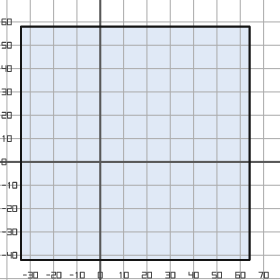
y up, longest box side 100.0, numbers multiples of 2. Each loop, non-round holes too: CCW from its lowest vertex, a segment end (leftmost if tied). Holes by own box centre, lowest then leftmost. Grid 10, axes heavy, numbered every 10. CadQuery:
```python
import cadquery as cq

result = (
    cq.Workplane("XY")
    .moveTo(-34.0, -42.0)
    .lineTo(64.0, -42.0)
    .lineTo(64.0, 58.0)
    .lineTo(-34.0, 58.0)
    .close()
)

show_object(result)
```